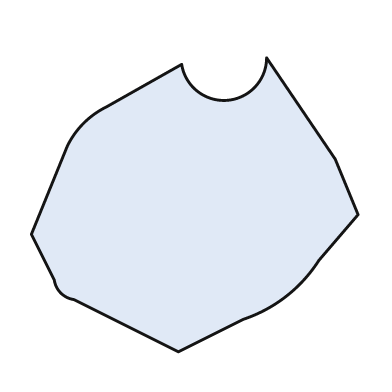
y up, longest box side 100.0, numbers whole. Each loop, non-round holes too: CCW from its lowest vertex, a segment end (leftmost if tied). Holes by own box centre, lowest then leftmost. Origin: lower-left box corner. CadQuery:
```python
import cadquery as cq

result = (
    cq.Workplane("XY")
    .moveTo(45.0, 0.0)
    .lineTo(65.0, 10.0)
    .threePointArc((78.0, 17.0), (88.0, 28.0))
    .lineTo(100.0, 42.0)
    .lineTo(93.0, 59.0)
    .lineTo(72.0, 90.0)
    .threePointArc((60.0, 77.0), (46.0, 88.0))
    .lineTo(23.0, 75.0)
    .threePointArc((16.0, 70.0), (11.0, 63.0))
    .lineTo(0.0, 36.0)
    .lineTo(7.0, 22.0)
    .threePointArc((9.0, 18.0), (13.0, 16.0))
    .close()
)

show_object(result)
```